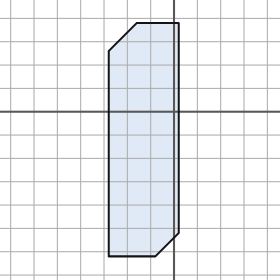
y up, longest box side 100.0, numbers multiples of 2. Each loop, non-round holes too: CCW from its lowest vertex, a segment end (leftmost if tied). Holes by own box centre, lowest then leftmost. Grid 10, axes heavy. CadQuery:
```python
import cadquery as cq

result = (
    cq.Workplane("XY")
    .moveTo(-28.0, -62.0)
    .lineTo(-8.0, -62.0)
    .lineTo(2.0, -52.0)
    .lineTo(2.0, 38.0)
    .lineTo(-16.0, 38.0)
    .lineTo(-28.0, 26.0)
    .close()
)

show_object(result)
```